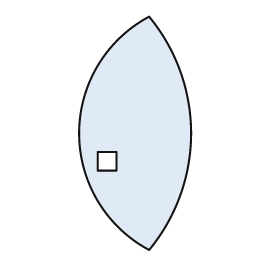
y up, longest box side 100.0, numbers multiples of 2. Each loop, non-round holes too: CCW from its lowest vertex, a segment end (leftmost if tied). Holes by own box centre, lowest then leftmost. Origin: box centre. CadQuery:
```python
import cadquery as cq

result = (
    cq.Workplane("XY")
    .moveTo(6.0, -50.0)
    .threePointArc((24.0, 0.0), (6.0, 50.0))
    .threePointArc((-24.0, 0.0), (6.0, -50.0))
    .close()
    .moveTo(-16.0, -16.0)
    .lineTo(-8.0, -16.0)
    .lineTo(-8.0, -8.0)
    .lineTo(-16.0, -8.0)
    .close()
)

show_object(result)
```